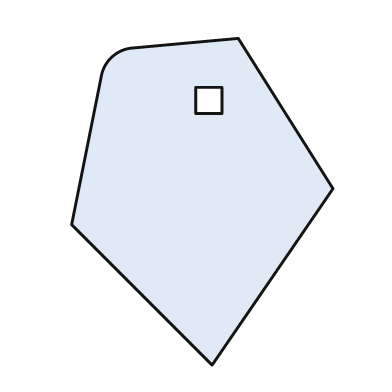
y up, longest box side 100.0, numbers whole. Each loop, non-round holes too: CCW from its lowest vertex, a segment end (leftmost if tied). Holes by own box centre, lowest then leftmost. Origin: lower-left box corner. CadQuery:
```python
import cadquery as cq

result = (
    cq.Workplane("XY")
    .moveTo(43.0, 0.0)
    .lineTo(80.0, 54.0)
    .lineTo(51.0, 100.0)
    .lineTo(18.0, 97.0)
    .threePointArc((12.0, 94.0), (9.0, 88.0))
    .lineTo(0.0, 43.0)
    .close()
    .moveTo(38.0, 77.0)
    .lineTo(46.0, 77.0)
    .lineTo(46.0, 85.0)
    .lineTo(38.0, 85.0)
    .close()
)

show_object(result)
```